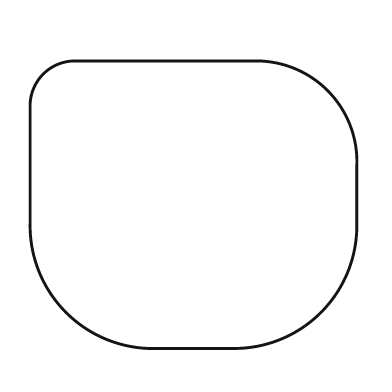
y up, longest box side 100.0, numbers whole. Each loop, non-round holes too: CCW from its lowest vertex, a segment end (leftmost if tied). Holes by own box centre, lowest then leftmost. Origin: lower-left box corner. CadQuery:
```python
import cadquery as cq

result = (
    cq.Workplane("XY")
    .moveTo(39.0, 0.0)
    .lineTo(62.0, 0.0)
    .threePointArc((89.0, 11.0), (100.0, 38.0))
    .lineTo(100.0, 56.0)
    .threePointArc((91.0, 79.0), (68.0, 88.0))
    .lineTo(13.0, 88.0)
    .threePointArc((4.0, 84.0), (0.0, 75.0))
    .lineTo(0.0, 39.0)
    .threePointArc((11.0, 11.0), (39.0, 0.0))
    .close()
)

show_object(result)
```